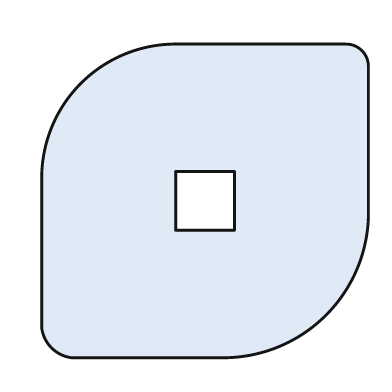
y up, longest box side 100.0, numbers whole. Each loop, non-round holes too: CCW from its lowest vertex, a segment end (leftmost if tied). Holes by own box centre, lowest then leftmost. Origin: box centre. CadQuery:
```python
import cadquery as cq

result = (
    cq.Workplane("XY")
    .moveTo(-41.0, -48.0)
    .lineTo(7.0, -48.0)
    .threePointArc((37.0, -35.0), (50.0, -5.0))
    .lineTo(50.0, 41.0)
    .threePointArc((48.0, 46.0), (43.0, 48.0))
    .lineTo(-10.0, 48.0)
    .threePointArc((-38.0, 36.0), (-50.0, 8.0))
    .lineTo(-50.0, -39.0)
    .threePointArc((-47.0, -45.0), (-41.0, -48.0))
    .close()
    .moveTo(-9.0, -9.0)
    .lineTo(9.0, -9.0)
    .lineTo(9.0, 9.0)
    .lineTo(-9.0, 9.0)
    .close()
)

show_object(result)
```